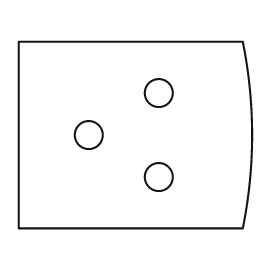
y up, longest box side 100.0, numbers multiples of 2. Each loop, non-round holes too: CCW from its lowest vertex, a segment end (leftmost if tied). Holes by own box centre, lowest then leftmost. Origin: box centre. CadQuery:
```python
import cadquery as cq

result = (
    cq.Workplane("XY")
    .moveTo(-50.0, -40.0)
    .lineTo(46.0, -40.0)
    .threePointArc((50.0, 0.0), (46.0, 40.0))
    .lineTo(-50.0, 40.0)
    .close()
    .moveTo(10.0, -18.0)
    .circle(6.0)
    .moveTo(-20.0, 0.0)
    .circle(6.0)
    .moveTo(10.0, 18.0)
    .circle(6.0)
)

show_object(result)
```